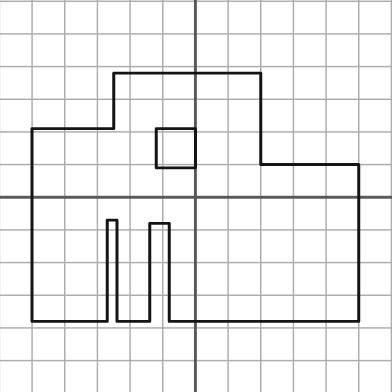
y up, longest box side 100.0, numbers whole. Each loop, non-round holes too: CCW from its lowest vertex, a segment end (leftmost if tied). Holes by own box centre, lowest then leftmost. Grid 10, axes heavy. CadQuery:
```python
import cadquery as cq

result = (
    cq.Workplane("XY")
    .moveTo(-50.0, -38.0)
    .lineTo(-27.0, -38.0)
    .lineTo(-27.0, -7.0)
    .lineTo(-24.0, -7.0)
    .lineTo(-24.0, -38.0)
    .lineTo(-14.0, -38.0)
    .lineTo(-14.0, -8.0)
    .lineTo(-8.0, -8.0)
    .lineTo(-8.0, -38.0)
    .lineTo(50.0, -38.0)
    .lineTo(50.0, 10.0)
    .lineTo(20.0, 10.0)
    .lineTo(20.0, 38.0)
    .lineTo(-25.0, 38.0)
    .lineTo(-25.0, 21.0)
    .lineTo(-50.0, 21.0)
    .close()
    .moveTo(-12.0, 9.0)
    .lineTo(0.0, 9.0)
    .lineTo(0.0, 21.0)
    .lineTo(-12.0, 21.0)
    .close()
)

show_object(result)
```